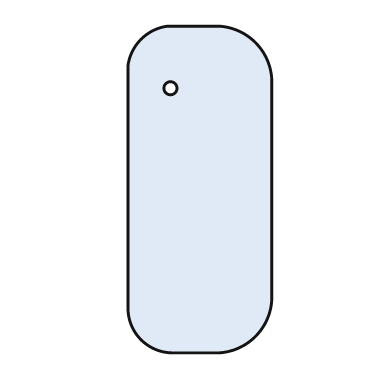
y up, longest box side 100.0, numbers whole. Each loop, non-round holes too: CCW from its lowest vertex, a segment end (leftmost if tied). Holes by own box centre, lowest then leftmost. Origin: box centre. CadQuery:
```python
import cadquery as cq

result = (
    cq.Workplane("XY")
    .moveTo(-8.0, -50.0)
    .lineTo(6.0, -50.0)
    .threePointArc((17.0, -45.0), (22.0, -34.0))
    .lineTo(22.0, 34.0)
    .threePointArc((17.0, 45.0), (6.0, 50.0))
    .lineTo(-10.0, 50.0)
    .threePointArc((-18.0, 46.0), (-22.0, 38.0))
    .lineTo(-22.0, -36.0)
    .threePointArc((-18.0, -46.0), (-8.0, -50.0))
    .close()
    .moveTo(-9.0, 31.0)
    .circle(2.0)
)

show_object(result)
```